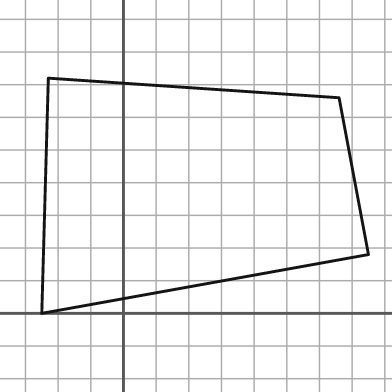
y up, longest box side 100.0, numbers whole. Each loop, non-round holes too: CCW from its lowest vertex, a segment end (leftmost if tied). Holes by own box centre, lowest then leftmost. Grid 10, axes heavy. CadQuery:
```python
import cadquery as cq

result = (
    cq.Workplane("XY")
    .moveTo(-25.0, 0.0)
    .lineTo(75.0, 18.0)
    .lineTo(66.0, 66.0)
    .lineTo(-23.0, 72.0)
    .close()
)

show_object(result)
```